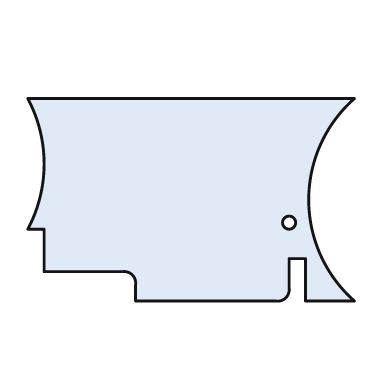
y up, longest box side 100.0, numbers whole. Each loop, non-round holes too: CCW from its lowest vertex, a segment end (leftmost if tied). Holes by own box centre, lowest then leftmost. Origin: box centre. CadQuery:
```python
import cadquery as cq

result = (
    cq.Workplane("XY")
    .moveTo(-17.0, -31.0)
    .lineTo(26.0, -31.0)
    .threePointArc((29.0, -30.0), (30.0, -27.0))
    .lineTo(30.0, -18.0)
    .lineTo(35.0, -18.0)
    .lineTo(35.0, -31.0)
    .lineTo(50.0, -31.0)
    .threePointArc((36.0, 0.0), (50.0, 31.0))
    .lineTo(-50.0, 31.0)
    .threePointArc((-45.0, 11.0), (-50.0, -9.0))
    .lineTo(-45.0, -9.0)
    .lineTo(-45.0, -22.0)
    .lineTo(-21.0, -22.0)
    .threePointArc((-18.0, -23.0), (-17.0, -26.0))
    .close()
    .moveTo(30.0, -7.0)
    .circle(2.0)
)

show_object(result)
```